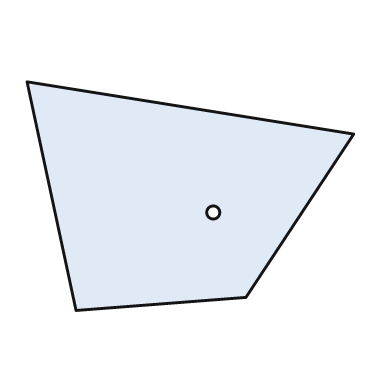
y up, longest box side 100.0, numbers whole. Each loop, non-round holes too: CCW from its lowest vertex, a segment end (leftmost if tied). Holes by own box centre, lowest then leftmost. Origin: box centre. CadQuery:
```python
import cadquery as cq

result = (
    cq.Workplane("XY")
    .moveTo(-35.0, -35.0)
    .lineTo(17.0, -31.0)
    .lineTo(50.0, 19.0)
    .lineTo(-50.0, 35.0)
    .close()
    .moveTo(7.0, -5.0)
    .circle(2.0)
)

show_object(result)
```